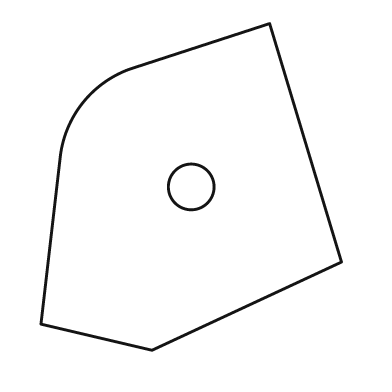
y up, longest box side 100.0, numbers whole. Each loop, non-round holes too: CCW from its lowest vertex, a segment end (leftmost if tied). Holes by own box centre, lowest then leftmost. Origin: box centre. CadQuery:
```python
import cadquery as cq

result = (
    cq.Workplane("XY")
    .moveTo(-12.0, -50.0)
    .lineTo(46.0, -23.0)
    .lineTo(24.0, 50.0)
    .lineTo(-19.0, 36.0)
    .threePointArc((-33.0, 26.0), (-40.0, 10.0))
    .lineTo(-46.0, -42.0)
    .close()
    .moveTo(0.0, 0.0)
    .circle(7.0)
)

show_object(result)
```